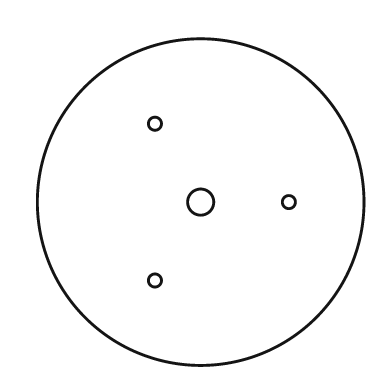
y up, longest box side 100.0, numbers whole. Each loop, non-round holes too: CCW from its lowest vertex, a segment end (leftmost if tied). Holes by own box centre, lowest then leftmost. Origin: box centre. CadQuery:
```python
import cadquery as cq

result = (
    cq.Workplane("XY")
    .moveTo(0.0, 0.0)
    .circle(50.0)
    .moveTo(-14.0, -24.0)
    .circle(2.0)
    .moveTo(0.0, 0.0)
    .circle(4.0)
    .moveTo(27.0, 0.0)
    .circle(2.0)
    .moveTo(-14.0, 24.0)
    .circle(2.0)
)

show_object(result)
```